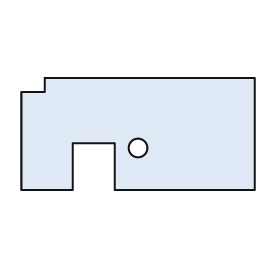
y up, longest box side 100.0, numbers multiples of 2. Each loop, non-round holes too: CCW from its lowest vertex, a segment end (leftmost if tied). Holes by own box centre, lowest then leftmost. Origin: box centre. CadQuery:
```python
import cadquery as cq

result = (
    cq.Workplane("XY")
    .moveTo(-50.0, -24.0)
    .lineTo(-28.0, -24.0)
    .lineTo(-28.0, -4.0)
    .lineTo(-10.0, -4.0)
    .lineTo(-10.0, -24.0)
    .lineTo(50.0, -24.0)
    .lineTo(50.0, 24.0)
    .lineTo(-40.0, 24.0)
    .lineTo(-40.0, 18.0)
    .lineTo(-50.0, 18.0)
    .close()
    .moveTo(0.0, -6.0)
    .circle(4.0)
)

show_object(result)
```